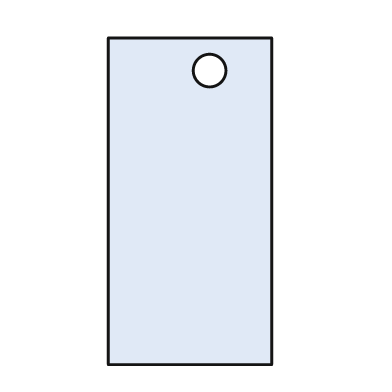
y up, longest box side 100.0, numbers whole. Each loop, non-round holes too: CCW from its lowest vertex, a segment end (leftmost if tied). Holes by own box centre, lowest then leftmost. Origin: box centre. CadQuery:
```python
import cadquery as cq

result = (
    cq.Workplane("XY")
    .moveTo(-25.0, -50.0)
    .lineTo(25.0, -50.0)
    .lineTo(25.0, 50.0)
    .lineTo(-25.0, 50.0)
    .close()
    .moveTo(6.0, 40.0)
    .circle(5.0)
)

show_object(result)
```